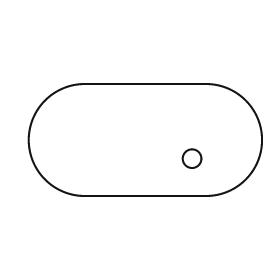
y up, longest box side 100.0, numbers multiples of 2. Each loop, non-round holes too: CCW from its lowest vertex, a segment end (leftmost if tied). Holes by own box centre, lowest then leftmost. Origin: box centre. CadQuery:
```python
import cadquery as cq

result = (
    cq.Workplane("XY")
    .moveTo(-26.0, -24.0)
    .lineTo(26.0, -24.0)
    .threePointArc((50.0, 0.0), (26.0, 24.0))
    .lineTo(-26.0, 24.0)
    .threePointArc((-50.0, 0.0), (-26.0, -24.0))
    .close()
    .moveTo(20.0, -8.0)
    .circle(4.0)
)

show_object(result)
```